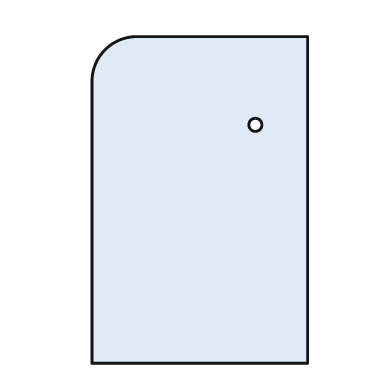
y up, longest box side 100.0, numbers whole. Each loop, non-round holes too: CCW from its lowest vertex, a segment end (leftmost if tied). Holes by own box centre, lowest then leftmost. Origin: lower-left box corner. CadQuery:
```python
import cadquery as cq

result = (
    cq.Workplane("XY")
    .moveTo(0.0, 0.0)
    .lineTo(66.0, 0.0)
    .lineTo(66.0, 100.0)
    .lineTo(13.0, 100.0)
    .threePointArc((4.0, 96.0), (0.0, 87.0))
    .close()
    .moveTo(50.0, 73.0)
    .circle(2.0)
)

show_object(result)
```